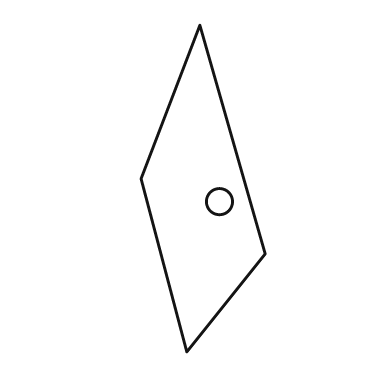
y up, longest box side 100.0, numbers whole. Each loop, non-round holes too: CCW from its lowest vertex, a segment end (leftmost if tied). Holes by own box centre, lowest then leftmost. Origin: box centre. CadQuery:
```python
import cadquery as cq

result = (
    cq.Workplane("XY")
    .moveTo(-5.0, -50.0)
    .lineTo(19.0, -20.0)
    .lineTo(-1.0, 50.0)
    .lineTo(-19.0, 3.0)
    .close()
    .moveTo(5.0, -4.0)
    .circle(4.0)
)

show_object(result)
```